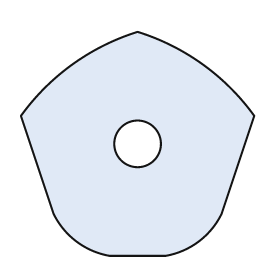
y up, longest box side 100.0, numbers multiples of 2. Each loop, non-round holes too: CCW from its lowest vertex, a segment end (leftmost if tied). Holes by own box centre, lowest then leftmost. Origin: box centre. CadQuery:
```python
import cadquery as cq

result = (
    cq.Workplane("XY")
    .moveTo(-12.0, -48.0)
    .lineTo(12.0, -48.0)
    .threePointArc((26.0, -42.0), (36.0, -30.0))
    .lineTo(50.0, 12.0)
    .threePointArc((28.0, 34.0), (0.0, 48.0))
    .threePointArc((-28.0, 34.0), (-50.0, 12.0))
    .lineTo(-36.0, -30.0)
    .threePointArc((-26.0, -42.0), (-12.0, -48.0))
    .close()
    .moveTo(0.0, 0.0)
    .circle(10.0)
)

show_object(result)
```